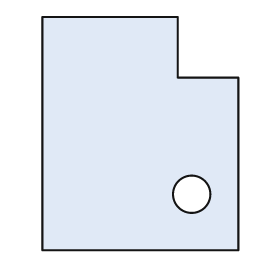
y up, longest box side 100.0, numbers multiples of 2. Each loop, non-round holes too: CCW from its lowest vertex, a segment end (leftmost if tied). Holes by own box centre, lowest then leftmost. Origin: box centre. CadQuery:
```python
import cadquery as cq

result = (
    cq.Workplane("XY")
    .moveTo(-42.0, -50.0)
    .lineTo(42.0, -50.0)
    .lineTo(42.0, 24.0)
    .lineTo(16.0, 24.0)
    .lineTo(16.0, 50.0)
    .lineTo(-42.0, 50.0)
    .close()
    .moveTo(22.0, -26.0)
    .circle(8.0)
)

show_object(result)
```